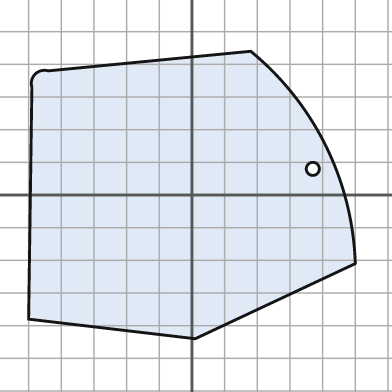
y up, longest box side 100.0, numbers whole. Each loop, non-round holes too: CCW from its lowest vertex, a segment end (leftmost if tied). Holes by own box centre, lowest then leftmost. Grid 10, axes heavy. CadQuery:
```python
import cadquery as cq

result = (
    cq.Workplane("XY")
    .moveTo(1.0, -44.0)
    .lineTo(50.0, -21.0)
    .threePointArc((41.0, 15.0), (18.0, 44.0))
    .lineTo(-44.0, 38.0)
    .threePointArc((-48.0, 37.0), (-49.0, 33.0))
    .lineTo(-50.0, -38.0)
    .close()
    .moveTo(37.0, 8.0)
    .circle(2.0)
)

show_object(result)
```